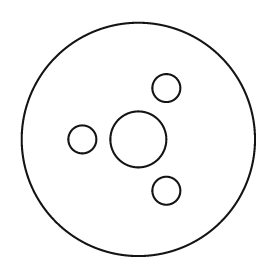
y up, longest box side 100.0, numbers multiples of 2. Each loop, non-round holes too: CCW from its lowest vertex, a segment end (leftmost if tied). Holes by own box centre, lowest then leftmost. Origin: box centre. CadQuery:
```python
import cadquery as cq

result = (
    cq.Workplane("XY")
    .moveTo(0.0, 0.0)
    .circle(50.0)
    .moveTo(12.0, -22.0)
    .circle(6.0)
    .moveTo(-24.0, 0.0)
    .circle(6.0)
    .moveTo(0.0, 0.0)
    .circle(12.0)
    .moveTo(12.0, 22.0)
    .circle(6.0)
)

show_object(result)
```